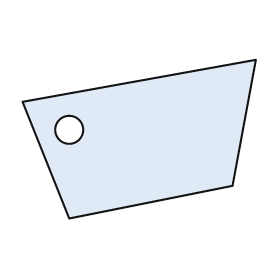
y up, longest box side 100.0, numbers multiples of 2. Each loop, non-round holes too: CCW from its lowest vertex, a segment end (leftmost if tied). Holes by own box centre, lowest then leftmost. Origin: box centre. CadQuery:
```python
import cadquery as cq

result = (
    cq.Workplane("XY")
    .moveTo(-30.0, -34.0)
    .lineTo(40.0, -20.0)
    .lineTo(50.0, 34.0)
    .lineTo(-50.0, 16.0)
    .close()
    .moveTo(-30.0, 4.0)
    .circle(6.0)
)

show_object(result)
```